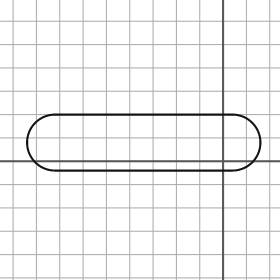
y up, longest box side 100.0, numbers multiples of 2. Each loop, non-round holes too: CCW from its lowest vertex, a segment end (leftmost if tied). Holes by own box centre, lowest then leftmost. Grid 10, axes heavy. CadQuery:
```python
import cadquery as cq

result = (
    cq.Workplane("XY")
    .moveTo(-72.0, -4.0)
    .lineTo(4.0, -4.0)
    .threePointArc((16.0, 8.0), (4.0, 20.0))
    .lineTo(-72.0, 20.0)
    .threePointArc((-84.0, 8.0), (-72.0, -4.0))
    .close()
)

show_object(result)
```